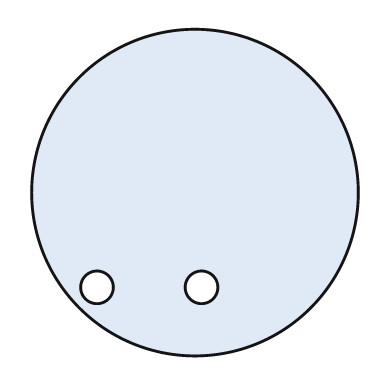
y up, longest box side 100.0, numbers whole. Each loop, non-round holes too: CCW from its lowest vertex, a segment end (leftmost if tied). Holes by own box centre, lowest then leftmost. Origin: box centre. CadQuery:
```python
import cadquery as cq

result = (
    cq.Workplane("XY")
    .moveTo(0.0, 0.0)
    .circle(50.0)
    .moveTo(-30.0, -29.0)
    .circle(5.0)
    .moveTo(2.0, -29.0)
    .circle(5.0)
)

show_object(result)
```